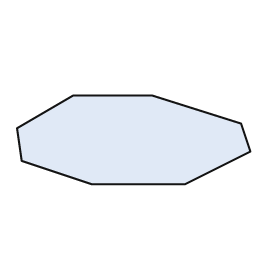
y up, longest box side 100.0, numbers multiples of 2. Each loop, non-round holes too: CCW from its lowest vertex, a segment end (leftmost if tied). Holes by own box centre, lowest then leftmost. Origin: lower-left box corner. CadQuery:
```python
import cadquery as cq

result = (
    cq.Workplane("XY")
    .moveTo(32.0, 0.0)
    .lineTo(72.0, 0.0)
    .lineTo(100.0, 14.0)
    .lineTo(96.0, 26.0)
    .lineTo(58.0, 38.0)
    .lineTo(24.0, 38.0)
    .lineTo(0.0, 24.0)
    .lineTo(2.0, 10.0)
    .close()
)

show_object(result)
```